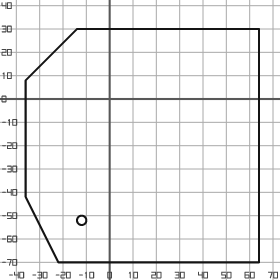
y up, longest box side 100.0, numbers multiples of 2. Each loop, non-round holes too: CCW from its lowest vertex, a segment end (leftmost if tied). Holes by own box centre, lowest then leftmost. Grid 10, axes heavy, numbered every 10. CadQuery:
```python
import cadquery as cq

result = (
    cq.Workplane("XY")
    .moveTo(-22.0, -70.0)
    .lineTo(64.0, -70.0)
    .lineTo(64.0, 30.0)
    .lineTo(-14.0, 30.0)
    .lineTo(-36.0, 8.0)
    .lineTo(-36.0, -42.0)
    .close()
    .moveTo(-12.0, -52.0)
    .circle(2.0)
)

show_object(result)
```